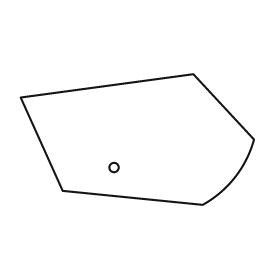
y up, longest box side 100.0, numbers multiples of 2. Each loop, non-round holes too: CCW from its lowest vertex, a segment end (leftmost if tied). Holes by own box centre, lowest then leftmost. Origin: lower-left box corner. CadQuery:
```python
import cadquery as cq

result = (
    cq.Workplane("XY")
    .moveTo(78.0, 0.0)
    .threePointArc((92.0, 12.0), (100.0, 28.0))
    .lineTo(74.0, 56.0)
    .lineTo(0.0, 46.0)
    .lineTo(18.0, 6.0)
    .close()
    .moveTo(40.0, 16.0)
    .circle(2.0)
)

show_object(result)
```